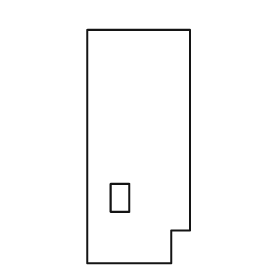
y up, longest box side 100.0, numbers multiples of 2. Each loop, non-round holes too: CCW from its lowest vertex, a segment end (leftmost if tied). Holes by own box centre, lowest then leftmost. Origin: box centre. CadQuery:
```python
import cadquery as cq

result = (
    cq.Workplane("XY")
    .moveTo(-22.0, -50.0)
    .lineTo(14.0, -50.0)
    .lineTo(14.0, -36.0)
    .lineTo(22.0, -36.0)
    .lineTo(22.0, 50.0)
    .lineTo(-22.0, 50.0)
    .close()
    .moveTo(-12.0, -28.0)
    .lineTo(-4.0, -28.0)
    .lineTo(-4.0, -16.0)
    .lineTo(-12.0, -16.0)
    .close()
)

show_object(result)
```